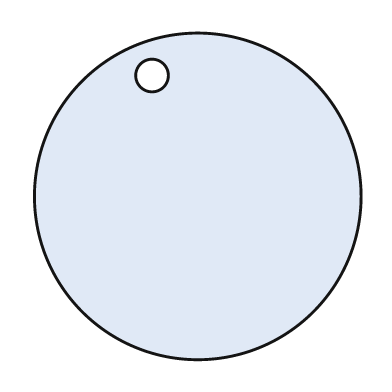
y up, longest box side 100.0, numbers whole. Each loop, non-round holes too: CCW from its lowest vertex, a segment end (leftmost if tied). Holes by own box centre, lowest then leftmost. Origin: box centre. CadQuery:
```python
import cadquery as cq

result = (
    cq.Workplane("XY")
    .moveTo(0.0, 0.0)
    .circle(50.0)
    .moveTo(-14.0, 37.0)
    .circle(5.0)
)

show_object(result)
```